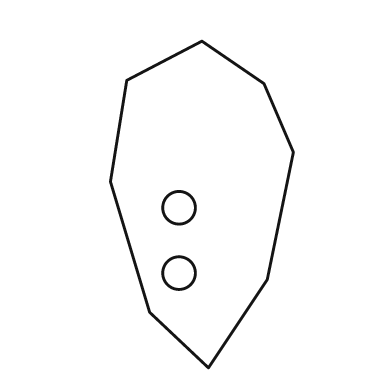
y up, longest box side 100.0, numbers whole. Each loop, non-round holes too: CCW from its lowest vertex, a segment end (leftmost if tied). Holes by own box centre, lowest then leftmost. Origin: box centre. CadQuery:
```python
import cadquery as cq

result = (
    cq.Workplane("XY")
    .moveTo(2.0, -50.0)
    .lineTo(20.0, -23.0)
    .lineTo(28.0, 16.0)
    .lineTo(19.0, 37.0)
    .lineTo(0.0, 50.0)
    .lineTo(-23.0, 38.0)
    .lineTo(-28.0, 7.0)
    .lineTo(-16.0, -33.0)
    .close()
    .moveTo(-7.0, -21.0)
    .circle(5.0)
    .moveTo(-7.0, -1.0)
    .circle(5.0)
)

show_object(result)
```